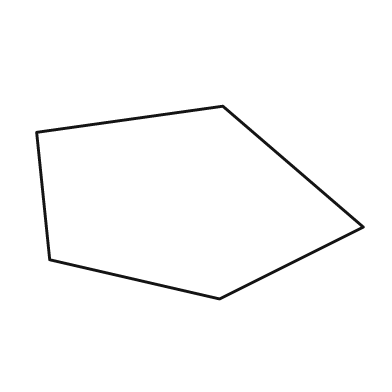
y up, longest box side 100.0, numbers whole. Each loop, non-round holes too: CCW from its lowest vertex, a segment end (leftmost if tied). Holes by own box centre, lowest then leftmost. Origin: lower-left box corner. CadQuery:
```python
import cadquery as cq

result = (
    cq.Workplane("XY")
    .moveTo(56.0, 0.0)
    .lineTo(100.0, 22.0)
    .lineTo(57.0, 59.0)
    .lineTo(0.0, 51.0)
    .lineTo(4.0, 12.0)
    .close()
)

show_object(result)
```